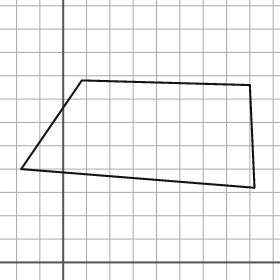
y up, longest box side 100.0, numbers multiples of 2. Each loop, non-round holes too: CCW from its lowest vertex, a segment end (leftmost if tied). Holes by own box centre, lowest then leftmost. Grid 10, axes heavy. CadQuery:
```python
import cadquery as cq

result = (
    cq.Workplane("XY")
    .moveTo(82.0, 32.0)
    .lineTo(80.0, 76.0)
    .lineTo(8.0, 78.0)
    .lineTo(-18.0, 40.0)
    .close()
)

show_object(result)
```